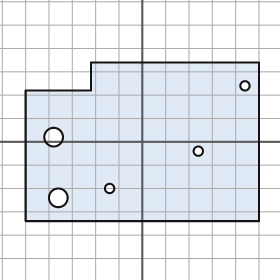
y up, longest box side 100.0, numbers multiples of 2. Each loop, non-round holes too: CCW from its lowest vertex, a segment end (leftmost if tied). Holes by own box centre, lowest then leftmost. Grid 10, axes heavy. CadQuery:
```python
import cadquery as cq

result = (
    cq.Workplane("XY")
    .moveTo(-50.0, -34.0)
    .lineTo(50.0, -34.0)
    .lineTo(50.0, 34.0)
    .lineTo(-22.0, 34.0)
    .lineTo(-22.0, 22.0)
    .lineTo(-50.0, 22.0)
    .close()
    .moveTo(-36.0, -24.0)
    .circle(4.0)
    .moveTo(-14.0, -20.0)
    .circle(2.0)
    .moveTo(24.0, -4.0)
    .circle(2.0)
    .moveTo(-38.0, 2.0)
    .circle(4.0)
    .moveTo(44.0, 24.0)
    .circle(2.0)
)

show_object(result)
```